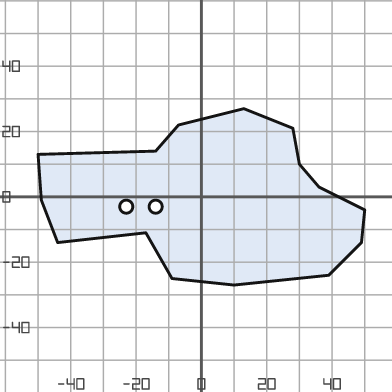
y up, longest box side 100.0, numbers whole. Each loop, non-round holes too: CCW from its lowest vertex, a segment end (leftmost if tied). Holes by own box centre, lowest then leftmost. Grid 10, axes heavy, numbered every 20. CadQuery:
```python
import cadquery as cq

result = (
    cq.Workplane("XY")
    .moveTo(10.0, -27.0)
    .lineTo(39.0, -24.0)
    .lineTo(49.0, -14.0)
    .lineTo(50.0, -4.0)
    .lineTo(36.0, 3.0)
    .lineTo(30.0, 10.0)
    .lineTo(28.0, 21.0)
    .lineTo(13.0, 27.0)
    .lineTo(-7.0, 22.0)
    .lineTo(-14.0, 14.0)
    .lineTo(-50.0, 13.0)
    .lineTo(-49.0, -1.0)
    .lineTo(-44.0, -14.0)
    .lineTo(-17.0, -11.0)
    .lineTo(-9.0, -25.0)
    .close()
    .moveTo(-23.0, -3.0)
    .circle(2.0)
    .moveTo(-14.0, -3.0)
    .circle(2.0)
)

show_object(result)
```